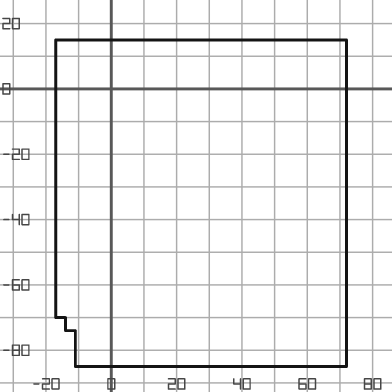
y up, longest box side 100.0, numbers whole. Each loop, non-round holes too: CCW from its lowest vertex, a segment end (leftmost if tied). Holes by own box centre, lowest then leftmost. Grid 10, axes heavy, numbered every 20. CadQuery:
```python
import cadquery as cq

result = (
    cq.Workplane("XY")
    .moveTo(-11.0, -85.0)
    .lineTo(72.0, -85.0)
    .lineTo(72.0, 15.0)
    .lineTo(-17.0, 15.0)
    .lineTo(-17.0, -70.0)
    .lineTo(-14.0, -70.0)
    .lineTo(-14.0, -74.0)
    .lineTo(-11.0, -74.0)
    .close()
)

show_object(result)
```